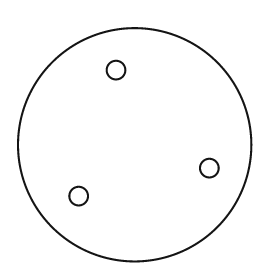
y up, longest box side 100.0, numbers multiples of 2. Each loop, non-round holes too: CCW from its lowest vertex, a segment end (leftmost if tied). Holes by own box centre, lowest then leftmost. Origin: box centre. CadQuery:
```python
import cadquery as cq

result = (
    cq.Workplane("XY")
    .moveTo(0.0, 0.0)
    .circle(50.0)
    .moveTo(-24.0, -22.0)
    .circle(4.0)
    .moveTo(32.0, -10.0)
    .circle(4.0)
    .moveTo(-8.0, 32.0)
    .circle(4.0)
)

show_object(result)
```